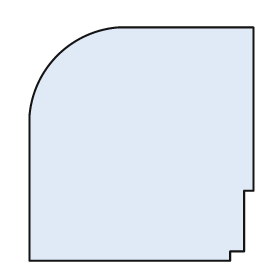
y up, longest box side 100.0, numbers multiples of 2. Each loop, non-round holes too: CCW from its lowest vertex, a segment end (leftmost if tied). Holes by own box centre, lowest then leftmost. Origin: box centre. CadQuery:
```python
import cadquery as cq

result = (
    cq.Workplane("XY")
    .moveTo(-48.0, -50.0)
    .lineTo(38.0, -50.0)
    .lineTo(38.0, -46.0)
    .lineTo(44.0, -46.0)
    .lineTo(44.0, -20.0)
    .lineTo(48.0, -20.0)
    .lineTo(48.0, 50.0)
    .lineTo(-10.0, 50.0)
    .threePointArc((-36.0, 38.0), (-48.0, 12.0))
    .close()
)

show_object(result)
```